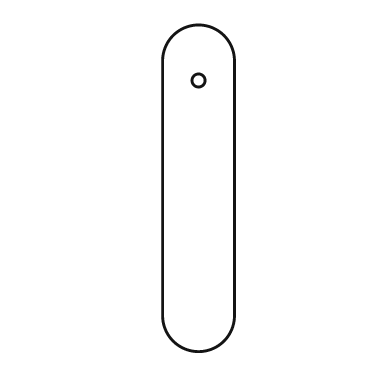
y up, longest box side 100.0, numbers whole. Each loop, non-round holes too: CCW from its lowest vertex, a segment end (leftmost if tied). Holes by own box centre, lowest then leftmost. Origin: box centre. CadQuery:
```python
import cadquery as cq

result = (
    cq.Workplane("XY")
    .moveTo(-11.0, -39.0)
    .threePointArc((0.0, -50.0), (11.0, -39.0))
    .lineTo(11.0, 39.0)
    .threePointArc((0.0, 50.0), (-11.0, 39.0))
    .close()
    .moveTo(0.0, 33.0)
    .circle(2.0)
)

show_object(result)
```